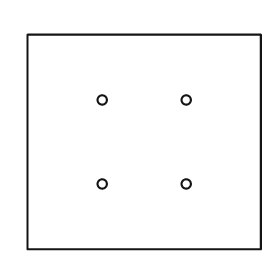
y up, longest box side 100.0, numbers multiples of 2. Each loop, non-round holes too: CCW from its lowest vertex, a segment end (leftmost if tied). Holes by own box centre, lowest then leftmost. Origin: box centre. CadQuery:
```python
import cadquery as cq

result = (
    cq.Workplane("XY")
    .moveTo(-50.0, -46.0)
    .lineTo(50.0, -46.0)
    .lineTo(50.0, 46.0)
    .lineTo(-50.0, 46.0)
    .close()
    .moveTo(-18.0, -18.0)
    .circle(2.0)
    .moveTo(18.0, -18.0)
    .circle(2.0)
    .moveTo(-18.0, 18.0)
    .circle(2.0)
    .moveTo(18.0, 18.0)
    .circle(2.0)
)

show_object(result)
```